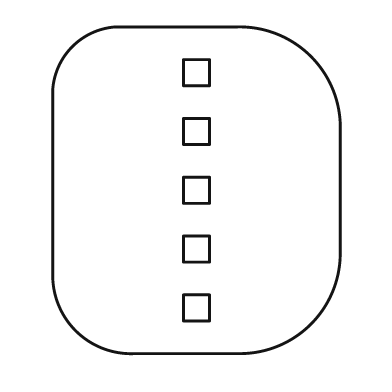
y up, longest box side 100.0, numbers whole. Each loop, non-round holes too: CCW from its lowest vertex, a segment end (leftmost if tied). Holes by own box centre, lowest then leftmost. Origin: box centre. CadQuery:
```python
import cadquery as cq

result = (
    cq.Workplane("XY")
    .moveTo(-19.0, -50.0)
    .lineTo(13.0, -50.0)
    .threePointArc((35.0, -41.0), (44.0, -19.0))
    .lineTo(44.0, 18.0)
    .threePointArc((35.0, 41.0), (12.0, 50.0))
    .lineTo(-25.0, 50.0)
    .threePointArc((-38.0, 44.0), (-44.0, 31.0))
    .lineTo(-44.0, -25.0)
    .threePointArc((-37.0, -43.0), (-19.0, -50.0))
    .close()
    .moveTo(-4.0, -40.0)
    .lineTo(4.0, -40.0)
    .lineTo(4.0, -32.0)
    .lineTo(-4.0, -32.0)
    .close()
    .moveTo(-4.0, -22.0)
    .lineTo(4.0, -22.0)
    .lineTo(4.0, -14.0)
    .lineTo(-4.0, -14.0)
    .close()
    .moveTo(-4.0, -4.0)
    .lineTo(4.0, -4.0)
    .lineTo(4.0, 4.0)
    .lineTo(-4.0, 4.0)
    .close()
    .moveTo(-4.0, 14.0)
    .lineTo(4.0, 14.0)
    .lineTo(4.0, 22.0)
    .lineTo(-4.0, 22.0)
    .close()
    .moveTo(-4.0, 32.0)
    .lineTo(4.0, 32.0)
    .lineTo(4.0, 40.0)
    .lineTo(-4.0, 40.0)
    .close()
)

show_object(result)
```